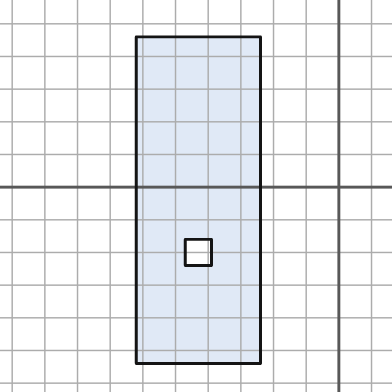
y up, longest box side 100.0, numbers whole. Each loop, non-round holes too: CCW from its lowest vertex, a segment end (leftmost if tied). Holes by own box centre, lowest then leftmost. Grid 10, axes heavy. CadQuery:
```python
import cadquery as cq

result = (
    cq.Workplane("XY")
    .moveTo(-62.0, -54.0)
    .lineTo(-24.0, -54.0)
    .lineTo(-24.0, 46.0)
    .lineTo(-62.0, 46.0)
    .close()
    .moveTo(-47.0, -24.0)
    .lineTo(-39.0, -24.0)
    .lineTo(-39.0, -16.0)
    .lineTo(-47.0, -16.0)
    .close()
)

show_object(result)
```